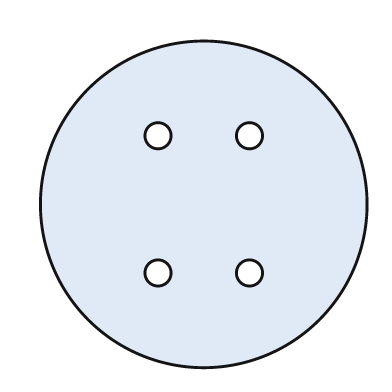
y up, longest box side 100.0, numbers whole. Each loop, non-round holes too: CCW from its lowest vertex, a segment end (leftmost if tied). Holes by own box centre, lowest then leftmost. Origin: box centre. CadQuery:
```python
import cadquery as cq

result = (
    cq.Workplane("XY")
    .moveTo(0.0, 0.0)
    .circle(50.0)
    .moveTo(-14.0, -21.0)
    .circle(4.0)
    .moveTo(14.0, -21.0)
    .circle(4.0)
    .moveTo(-14.0, 21.0)
    .circle(4.0)
    .moveTo(14.0, 21.0)
    .circle(4.0)
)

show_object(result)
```